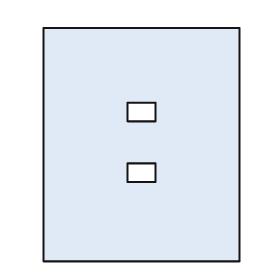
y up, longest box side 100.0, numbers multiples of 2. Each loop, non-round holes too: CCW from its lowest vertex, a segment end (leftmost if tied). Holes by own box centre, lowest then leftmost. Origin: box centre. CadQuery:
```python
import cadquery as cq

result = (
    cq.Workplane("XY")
    .moveTo(-42.0, -50.0)
    .lineTo(42.0, -50.0)
    .lineTo(42.0, 50.0)
    .lineTo(-42.0, 50.0)
    .close()
    .moveTo(-6.0, -16.0)
    .lineTo(6.0, -16.0)
    .lineTo(6.0, -8.0)
    .lineTo(-6.0, -8.0)
    .close()
    .moveTo(-6.0, 10.0)
    .lineTo(6.0, 10.0)
    .lineTo(6.0, 18.0)
    .lineTo(-6.0, 18.0)
    .close()
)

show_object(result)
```